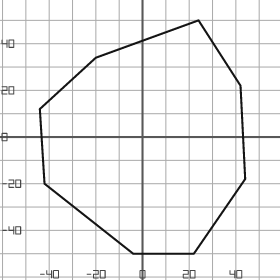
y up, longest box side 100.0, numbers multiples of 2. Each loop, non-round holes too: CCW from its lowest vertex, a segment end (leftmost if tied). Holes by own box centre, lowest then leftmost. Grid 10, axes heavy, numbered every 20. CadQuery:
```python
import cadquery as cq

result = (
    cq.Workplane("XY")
    .moveTo(-4.0, -50.0)
    .lineTo(22.0, -50.0)
    .lineTo(44.0, -18.0)
    .lineTo(42.0, 22.0)
    .lineTo(24.0, 50.0)
    .lineTo(-20.0, 34.0)
    .lineTo(-44.0, 12.0)
    .lineTo(-42.0, -20.0)
    .close()
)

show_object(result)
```